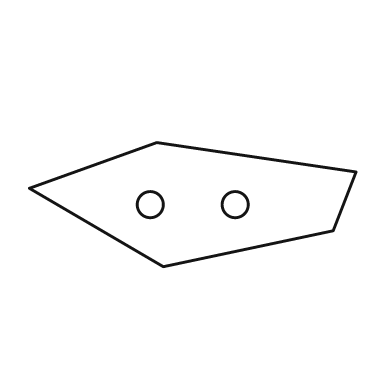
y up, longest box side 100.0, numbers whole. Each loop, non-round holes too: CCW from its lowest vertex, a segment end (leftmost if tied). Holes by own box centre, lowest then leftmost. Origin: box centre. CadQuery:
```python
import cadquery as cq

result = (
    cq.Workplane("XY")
    .moveTo(-9.0, -19.0)
    .lineTo(43.0, -8.0)
    .lineTo(50.0, 10.0)
    .lineTo(-11.0, 19.0)
    .lineTo(-50.0, 5.0)
    .close()
    .moveTo(-13.0, 0.0)
    .circle(4.0)
    .moveTo(13.0, 0.0)
    .circle(4.0)
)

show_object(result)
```